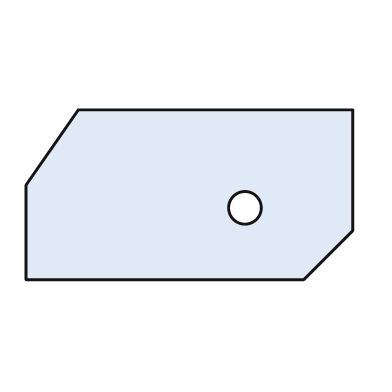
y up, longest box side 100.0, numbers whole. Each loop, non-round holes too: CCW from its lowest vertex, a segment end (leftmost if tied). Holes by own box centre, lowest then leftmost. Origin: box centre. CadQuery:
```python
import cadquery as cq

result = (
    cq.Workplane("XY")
    .moveTo(-50.0, -26.0)
    .lineTo(35.0, -26.0)
    .lineTo(50.0, -11.0)
    .lineTo(50.0, 26.0)
    .lineTo(-34.0, 26.0)
    .lineTo(-50.0, 3.0)
    .close()
    .moveTo(17.0, -4.0)
    .circle(5.0)
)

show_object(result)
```